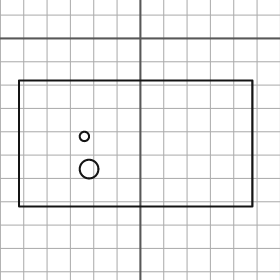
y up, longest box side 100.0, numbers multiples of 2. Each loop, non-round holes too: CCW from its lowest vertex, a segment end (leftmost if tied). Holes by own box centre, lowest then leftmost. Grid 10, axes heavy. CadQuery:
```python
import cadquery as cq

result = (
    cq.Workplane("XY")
    .moveTo(-52.0, -72.0)
    .lineTo(48.0, -72.0)
    .lineTo(48.0, -18.0)
    .lineTo(-52.0, -18.0)
    .close()
    .moveTo(-22.0, -56.0)
    .circle(4.0)
    .moveTo(-24.0, -42.0)
    .circle(2.0)
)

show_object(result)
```